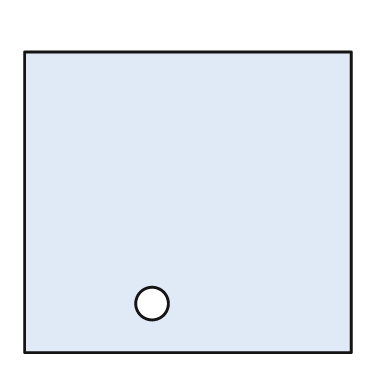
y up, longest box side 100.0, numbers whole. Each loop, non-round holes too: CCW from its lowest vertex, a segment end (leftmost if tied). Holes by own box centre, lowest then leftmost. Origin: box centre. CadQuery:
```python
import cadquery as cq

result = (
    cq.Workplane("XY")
    .moveTo(-50.0, -46.0)
    .lineTo(50.0, -46.0)
    .lineTo(50.0, 46.0)
    .lineTo(-50.0, 46.0)
    .close()
    .moveTo(-11.0, -31.0)
    .circle(5.0)
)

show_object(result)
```